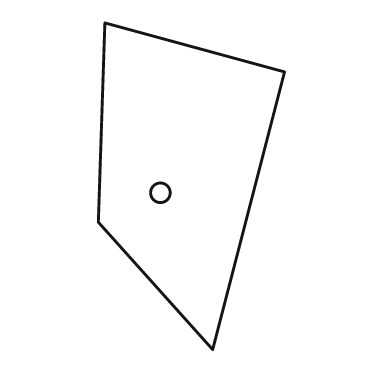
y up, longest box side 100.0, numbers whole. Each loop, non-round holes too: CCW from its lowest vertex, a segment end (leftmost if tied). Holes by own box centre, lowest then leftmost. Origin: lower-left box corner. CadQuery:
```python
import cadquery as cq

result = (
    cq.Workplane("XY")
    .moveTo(35.0, 0.0)
    .lineTo(57.0, 85.0)
    .lineTo(2.0, 100.0)
    .lineTo(0.0, 39.0)
    .close()
    .moveTo(19.0, 48.0)
    .circle(3.0)
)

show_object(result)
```